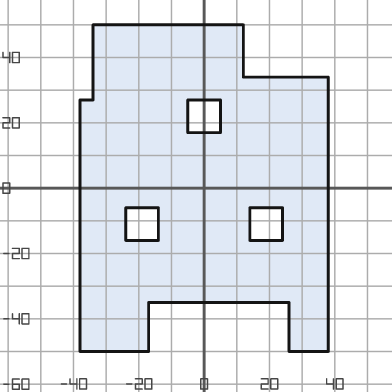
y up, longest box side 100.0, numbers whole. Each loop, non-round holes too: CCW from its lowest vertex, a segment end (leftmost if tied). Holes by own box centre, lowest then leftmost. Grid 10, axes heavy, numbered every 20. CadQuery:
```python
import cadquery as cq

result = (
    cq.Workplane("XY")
    .moveTo(-38.0, -50.0)
    .lineTo(-17.0, -50.0)
    .lineTo(-17.0, -35.0)
    .lineTo(26.0, -35.0)
    .lineTo(26.0, -50.0)
    .lineTo(38.0, -50.0)
    .lineTo(38.0, 34.0)
    .lineTo(12.0, 34.0)
    .lineTo(12.0, 50.0)
    .lineTo(-34.0, 50.0)
    .lineTo(-34.0, 27.0)
    .lineTo(-38.0, 27.0)
    .close()
    .moveTo(-24.0, -16.0)
    .lineTo(-14.0, -16.0)
    .lineTo(-14.0, -6.0)
    .lineTo(-24.0, -6.0)
    .close()
    .moveTo(14.0, -16.0)
    .lineTo(24.0, -16.0)
    .lineTo(24.0, -6.0)
    .lineTo(14.0, -6.0)
    .close()
    .moveTo(-5.0, 17.0)
    .lineTo(5.0, 17.0)
    .lineTo(5.0, 27.0)
    .lineTo(-5.0, 27.0)
    .close()
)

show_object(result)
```